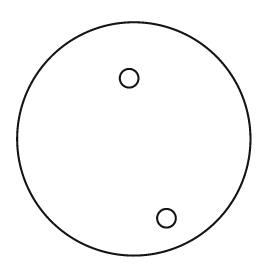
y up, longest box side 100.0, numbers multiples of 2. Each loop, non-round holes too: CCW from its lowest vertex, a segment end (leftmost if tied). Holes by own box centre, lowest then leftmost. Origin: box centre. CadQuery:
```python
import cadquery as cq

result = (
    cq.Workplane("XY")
    .moveTo(0.0, 0.0)
    .circle(50.0)
    .moveTo(14.0, -34.0)
    .circle(4.0)
    .moveTo(-2.0, 26.0)
    .circle(4.0)
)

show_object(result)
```